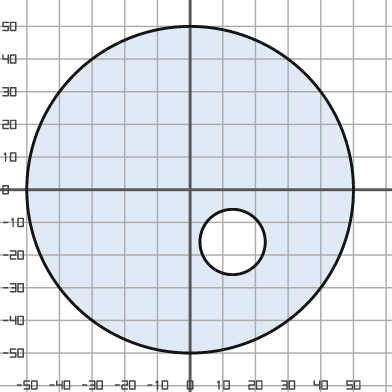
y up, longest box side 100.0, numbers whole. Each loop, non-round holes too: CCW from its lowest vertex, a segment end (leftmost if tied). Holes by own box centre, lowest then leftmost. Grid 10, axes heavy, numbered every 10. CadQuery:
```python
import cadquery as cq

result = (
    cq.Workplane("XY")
    .moveTo(0.0, 0.0)
    .circle(50.0)
    .moveTo(13.0, -16.0)
    .circle(10.0)
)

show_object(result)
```